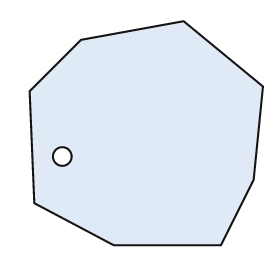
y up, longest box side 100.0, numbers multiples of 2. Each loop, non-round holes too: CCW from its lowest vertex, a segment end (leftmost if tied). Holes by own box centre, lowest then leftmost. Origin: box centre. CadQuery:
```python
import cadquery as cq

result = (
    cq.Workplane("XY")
    .moveTo(-14.0, -48.0)
    .lineTo(32.0, -48.0)
    .lineTo(46.0, -20.0)
    .lineTo(50.0, 20.0)
    .lineTo(16.0, 48.0)
    .lineTo(-28.0, 40.0)
    .lineTo(-50.0, 18.0)
    .lineTo(-48.0, -30.0)
    .close()
    .moveTo(-36.0, -10.0)
    .circle(4.0)
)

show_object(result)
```